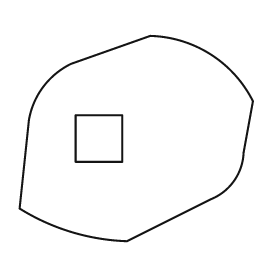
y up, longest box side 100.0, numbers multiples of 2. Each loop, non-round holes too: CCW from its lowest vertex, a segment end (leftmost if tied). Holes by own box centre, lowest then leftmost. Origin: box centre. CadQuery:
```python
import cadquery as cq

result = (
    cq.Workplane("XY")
    .moveTo(-4.0, -44.0)
    .lineTo(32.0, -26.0)
    .threePointArc((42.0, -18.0), (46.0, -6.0))
    .lineTo(50.0, 16.0)
    .threePointArc((32.0, 36.0), (6.0, 44.0))
    .lineTo(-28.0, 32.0)
    .threePointArc((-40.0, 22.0), (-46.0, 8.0))
    .lineTo(-50.0, -30.0)
    .threePointArc((-28.0, -40.0), (-4.0, -44.0))
    .close()
    .moveTo(-26.0, -10.0)
    .lineTo(-6.0, -10.0)
    .lineTo(-6.0, 10.0)
    .lineTo(-26.0, 10.0)
    .close()
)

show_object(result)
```